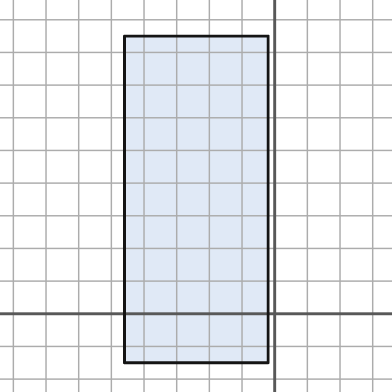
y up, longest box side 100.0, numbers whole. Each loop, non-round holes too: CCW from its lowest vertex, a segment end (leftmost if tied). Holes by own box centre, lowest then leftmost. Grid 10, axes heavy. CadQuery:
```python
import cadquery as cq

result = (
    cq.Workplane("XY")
    .moveTo(-46.0, -15.0)
    .lineTo(-2.0, -15.0)
    .lineTo(-2.0, 85.0)
    .lineTo(-46.0, 85.0)
    .close()
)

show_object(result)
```